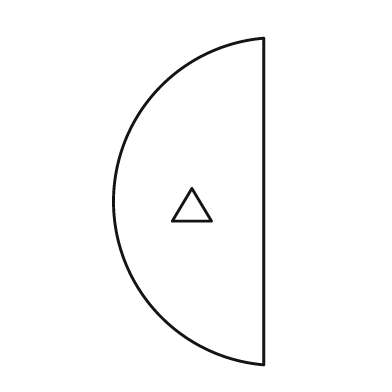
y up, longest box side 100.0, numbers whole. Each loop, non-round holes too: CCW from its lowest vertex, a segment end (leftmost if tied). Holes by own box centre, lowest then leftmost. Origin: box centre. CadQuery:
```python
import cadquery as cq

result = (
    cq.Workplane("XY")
    .moveTo(23.0, -50.0)
    .lineTo(23.0, 50.0)
    .threePointArc((-23.0, 0.0), (23.0, -50.0))
    .close()
    .moveTo(-5.0, -6.0)
    .lineTo(7.0, -6.0)
    .lineTo(1.0, 4.0)
    .close()
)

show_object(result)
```